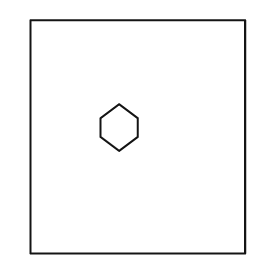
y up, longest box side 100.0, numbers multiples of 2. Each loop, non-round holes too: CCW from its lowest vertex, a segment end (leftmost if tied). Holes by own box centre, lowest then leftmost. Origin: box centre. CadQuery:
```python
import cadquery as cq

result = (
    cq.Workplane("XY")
    .moveTo(-46.0, -50.0)
    .lineTo(46.0, -50.0)
    .lineTo(46.0, 50.0)
    .lineTo(-46.0, 50.0)
    .close()
    .moveTo(-8.0, -6.0)
    .lineTo(0.0, 0.0)
    .lineTo(0.0, 8.0)
    .lineTo(-8.0, 14.0)
    .lineTo(-16.0, 8.0)
    .lineTo(-16.0, 0.0)
    .close()
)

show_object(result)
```